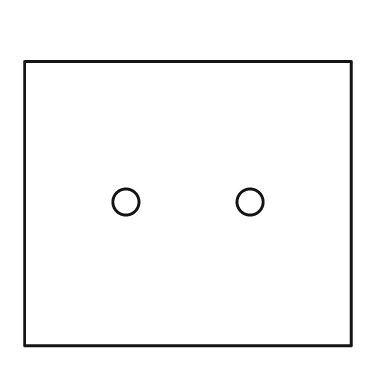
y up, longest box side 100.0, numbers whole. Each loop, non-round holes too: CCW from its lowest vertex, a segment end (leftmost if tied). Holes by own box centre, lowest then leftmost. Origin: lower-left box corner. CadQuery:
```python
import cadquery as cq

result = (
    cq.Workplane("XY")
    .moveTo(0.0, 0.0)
    .lineTo(100.0, 0.0)
    .lineTo(100.0, 87.0)
    .lineTo(0.0, 87.0)
    .close()
    .moveTo(31.0, 44.0)
    .circle(4.0)
    .moveTo(69.0, 44.0)
    .circle(4.0)
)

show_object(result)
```